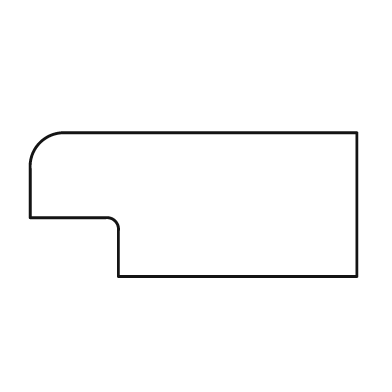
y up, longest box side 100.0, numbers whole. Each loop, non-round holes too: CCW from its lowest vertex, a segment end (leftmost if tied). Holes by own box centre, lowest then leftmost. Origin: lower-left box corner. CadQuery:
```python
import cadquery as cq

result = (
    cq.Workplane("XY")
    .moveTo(27.0, 0.0)
    .lineTo(100.0, 0.0)
    .lineTo(100.0, 44.0)
    .lineTo(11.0, 44.0)
    .threePointArc((3.0, 41.0), (0.0, 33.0))
    .lineTo(0.0, 18.0)
    .lineTo(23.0, 18.0)
    .threePointArc((26.0, 17.0), (27.0, 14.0))
    .close()
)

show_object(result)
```